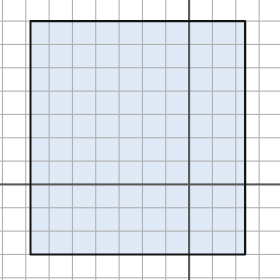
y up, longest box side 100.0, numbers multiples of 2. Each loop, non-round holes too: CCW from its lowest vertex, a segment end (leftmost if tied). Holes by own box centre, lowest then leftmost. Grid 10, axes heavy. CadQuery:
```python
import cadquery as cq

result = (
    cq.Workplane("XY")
    .moveTo(-68.0, -30.0)
    .lineTo(24.0, -30.0)
    .lineTo(24.0, 70.0)
    .lineTo(-68.0, 70.0)
    .close()
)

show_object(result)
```